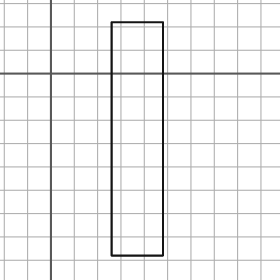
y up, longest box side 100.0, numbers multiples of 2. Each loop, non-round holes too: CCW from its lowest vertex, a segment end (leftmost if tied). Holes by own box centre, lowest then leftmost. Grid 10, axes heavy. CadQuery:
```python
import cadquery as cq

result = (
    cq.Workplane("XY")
    .moveTo(26.0, -78.0)
    .lineTo(48.0, -78.0)
    .lineTo(48.0, 22.0)
    .lineTo(26.0, 22.0)
    .close()
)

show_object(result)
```